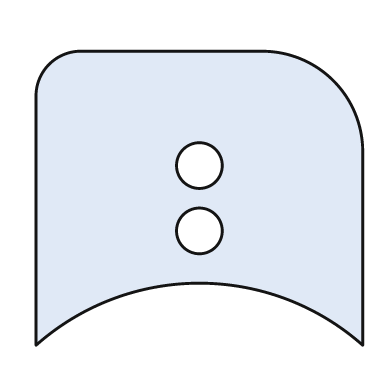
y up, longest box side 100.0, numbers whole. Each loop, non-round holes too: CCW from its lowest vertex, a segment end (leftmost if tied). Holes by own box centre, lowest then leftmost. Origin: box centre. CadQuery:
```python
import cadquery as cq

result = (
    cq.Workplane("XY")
    .moveTo(-50.0, -45.0)
    .threePointArc((0.0, -26.0), (50.0, -45.0))
    .lineTo(50.0, 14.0)
    .threePointArc((41.0, 36.0), (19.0, 45.0))
    .lineTo(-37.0, 45.0)
    .threePointArc((-46.0, 41.0), (-50.0, 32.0))
    .close()
    .moveTo(0.0, -10.0)
    .circle(7.0)
    .moveTo(0.0, 10.0)
    .circle(7.0)
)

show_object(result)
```